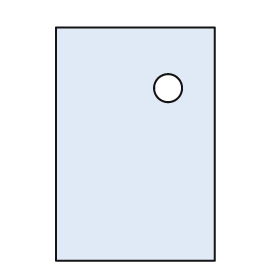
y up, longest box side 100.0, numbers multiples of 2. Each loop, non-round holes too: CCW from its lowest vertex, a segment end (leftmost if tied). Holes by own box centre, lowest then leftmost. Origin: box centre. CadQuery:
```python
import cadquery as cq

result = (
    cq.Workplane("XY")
    .moveTo(-34.0, -50.0)
    .lineTo(34.0, -50.0)
    .lineTo(34.0, 50.0)
    .lineTo(-34.0, 50.0)
    .close()
    .moveTo(14.0, 24.0)
    .circle(6.0)
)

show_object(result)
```